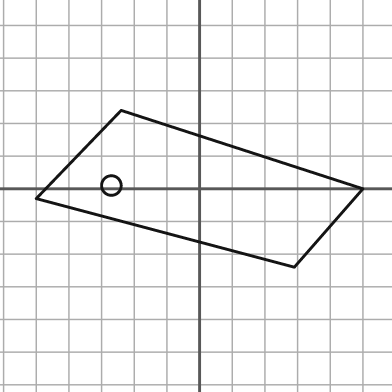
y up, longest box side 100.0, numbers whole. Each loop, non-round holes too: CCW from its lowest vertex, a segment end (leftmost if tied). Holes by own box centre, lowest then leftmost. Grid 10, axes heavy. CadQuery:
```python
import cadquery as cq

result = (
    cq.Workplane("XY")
    .moveTo(29.0, -24.0)
    .lineTo(50.0, 0.0)
    .lineTo(-24.0, 24.0)
    .lineTo(-50.0, -3.0)
    .close()
    .moveTo(-27.0, 1.0)
    .circle(3.0)
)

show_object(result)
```